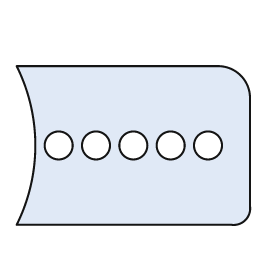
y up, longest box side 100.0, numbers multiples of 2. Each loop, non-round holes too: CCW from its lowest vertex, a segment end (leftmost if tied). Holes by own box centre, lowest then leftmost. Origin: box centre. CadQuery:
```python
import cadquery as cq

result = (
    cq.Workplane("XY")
    .moveTo(-50.0, -34.0)
    .lineTo(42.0, -34.0)
    .threePointArc((48.0, -32.0), (50.0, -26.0))
    .lineTo(50.0, 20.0)
    .threePointArc((46.0, 30.0), (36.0, 34.0))
    .lineTo(-50.0, 34.0)
    .threePointArc((-42.0, 0.0), (-50.0, -34.0))
    .close()
    .moveTo(-32.0, 0.0)
    .circle(6.0)
    .moveTo(-16.0, 0.0)
    .circle(6.0)
    .moveTo(0.0, 0.0)
    .circle(6.0)
    .moveTo(16.0, 0.0)
    .circle(6.0)
    .moveTo(32.0, 0.0)
    .circle(6.0)
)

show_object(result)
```